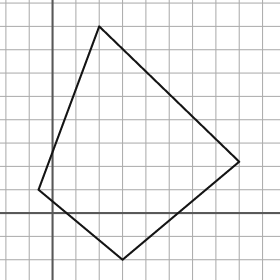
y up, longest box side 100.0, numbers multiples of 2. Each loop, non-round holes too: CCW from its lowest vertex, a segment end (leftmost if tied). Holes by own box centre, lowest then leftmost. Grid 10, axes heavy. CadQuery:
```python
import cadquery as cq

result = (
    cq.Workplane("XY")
    .moveTo(30.0, -20.0)
    .lineTo(80.0, 22.0)
    .lineTo(20.0, 80.0)
    .lineTo(-6.0, 10.0)
    .close()
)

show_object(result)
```